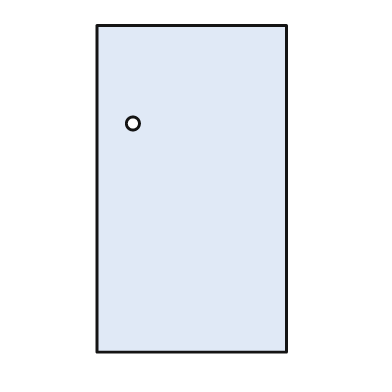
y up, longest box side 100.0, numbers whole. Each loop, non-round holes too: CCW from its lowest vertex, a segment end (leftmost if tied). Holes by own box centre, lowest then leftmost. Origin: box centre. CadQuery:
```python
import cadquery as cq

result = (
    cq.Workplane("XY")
    .moveTo(-29.0, -50.0)
    .lineTo(29.0, -50.0)
    .lineTo(29.0, 50.0)
    .lineTo(-29.0, 50.0)
    .close()
    .moveTo(-18.0, 20.0)
    .circle(2.0)
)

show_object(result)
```